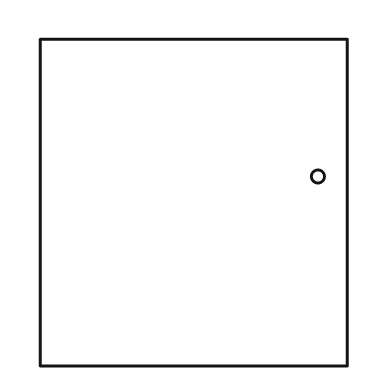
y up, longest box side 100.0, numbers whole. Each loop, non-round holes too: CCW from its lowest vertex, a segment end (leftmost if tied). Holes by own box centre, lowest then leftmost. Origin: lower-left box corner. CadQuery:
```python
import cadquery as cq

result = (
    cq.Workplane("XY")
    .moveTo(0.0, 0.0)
    .lineTo(94.0, 0.0)
    .lineTo(94.0, 100.0)
    .lineTo(0.0, 100.0)
    .close()
    .moveTo(85.0, 58.0)
    .circle(2.0)
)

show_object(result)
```